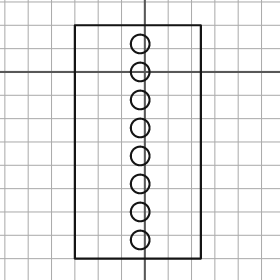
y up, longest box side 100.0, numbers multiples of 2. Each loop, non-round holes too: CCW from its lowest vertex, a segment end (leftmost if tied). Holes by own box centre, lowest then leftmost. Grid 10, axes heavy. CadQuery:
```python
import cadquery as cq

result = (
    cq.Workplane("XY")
    .moveTo(-30.0, -80.0)
    .lineTo(24.0, -80.0)
    .lineTo(24.0, 20.0)
    .lineTo(-30.0, 20.0)
    .close()
    .moveTo(-2.0, -72.0)
    .circle(4.0)
    .moveTo(-2.0, -60.0)
    .circle(4.0)
    .moveTo(-2.0, -48.0)
    .circle(4.0)
    .moveTo(-2.0, -36.0)
    .circle(4.0)
    .moveTo(-2.0, -24.0)
    .circle(4.0)
    .moveTo(-2.0, -12.0)
    .circle(4.0)
    .moveTo(-2.0, 0.0)
    .circle(4.0)
    .moveTo(-2.0, 12.0)
    .circle(4.0)
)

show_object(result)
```